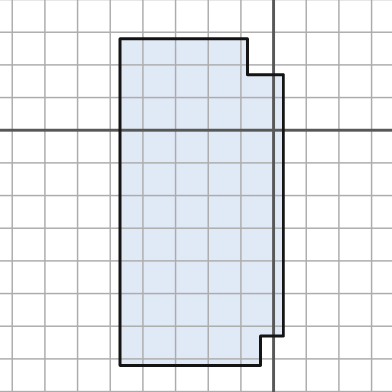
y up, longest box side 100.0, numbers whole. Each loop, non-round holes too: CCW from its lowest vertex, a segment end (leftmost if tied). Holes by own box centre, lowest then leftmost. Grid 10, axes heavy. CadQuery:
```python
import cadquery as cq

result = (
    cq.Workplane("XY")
    .moveTo(-47.0, -72.0)
    .lineTo(-4.0, -72.0)
    .lineTo(-4.0, -63.0)
    .lineTo(3.0, -63.0)
    .lineTo(3.0, 17.0)
    .lineTo(-8.0, 17.0)
    .lineTo(-8.0, 28.0)
    .lineTo(-47.0, 28.0)
    .close()
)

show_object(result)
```